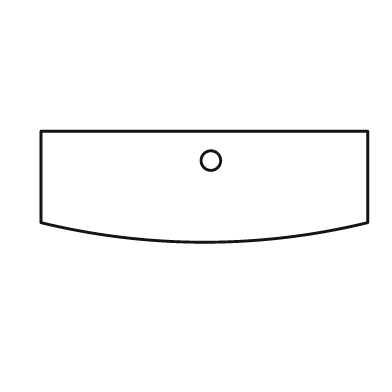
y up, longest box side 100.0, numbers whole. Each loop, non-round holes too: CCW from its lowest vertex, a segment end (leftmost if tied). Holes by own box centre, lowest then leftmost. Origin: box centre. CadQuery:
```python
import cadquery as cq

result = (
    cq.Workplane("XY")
    .moveTo(-50.0, -11.0)
    .threePointArc((0.0, -17.0), (50.0, -11.0))
    .lineTo(50.0, 17.0)
    .lineTo(-50.0, 17.0)
    .close()
    .moveTo(2.0, 8.0)
    .circle(3.0)
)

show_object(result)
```